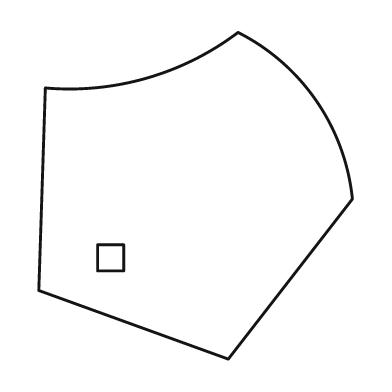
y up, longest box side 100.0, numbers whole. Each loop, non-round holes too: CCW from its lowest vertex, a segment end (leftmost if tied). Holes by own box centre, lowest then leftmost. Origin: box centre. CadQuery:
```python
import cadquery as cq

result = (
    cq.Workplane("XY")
    .moveTo(10.0, -50.0)
    .lineTo(48.0, -1.0)
    .threePointArc((37.0, 29.0), (13.0, 50.0))
    .threePointArc((-15.0, 36.0), (-46.0, 33.0))
    .lineTo(-48.0, -29.0)
    .close()
    .moveTo(-30.0, -23.0)
    .lineTo(-22.0, -23.0)
    .lineTo(-22.0, -15.0)
    .lineTo(-30.0, -15.0)
    .close()
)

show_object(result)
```